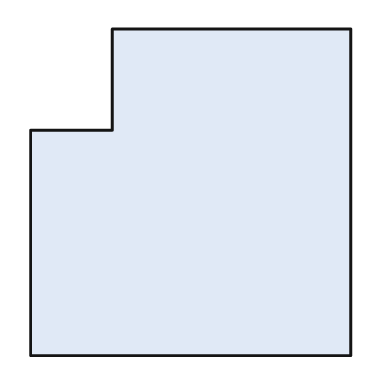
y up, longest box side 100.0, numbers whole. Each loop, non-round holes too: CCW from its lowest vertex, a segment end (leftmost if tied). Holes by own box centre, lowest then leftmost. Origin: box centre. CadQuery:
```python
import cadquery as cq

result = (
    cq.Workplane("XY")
    .moveTo(-49.0, -50.0)
    .lineTo(49.0, -50.0)
    .lineTo(49.0, 50.0)
    .lineTo(-24.0, 50.0)
    .lineTo(-24.0, 19.0)
    .lineTo(-49.0, 19.0)
    .close()
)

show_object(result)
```